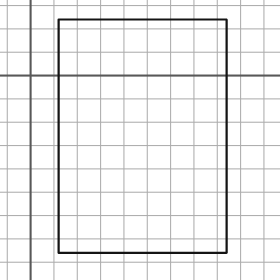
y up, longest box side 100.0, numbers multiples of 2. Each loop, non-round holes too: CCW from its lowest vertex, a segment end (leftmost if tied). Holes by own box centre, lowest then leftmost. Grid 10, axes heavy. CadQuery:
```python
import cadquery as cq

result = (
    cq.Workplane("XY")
    .moveTo(12.0, -76.0)
    .lineTo(84.0, -76.0)
    .lineTo(84.0, 24.0)
    .lineTo(12.0, 24.0)
    .close()
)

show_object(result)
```